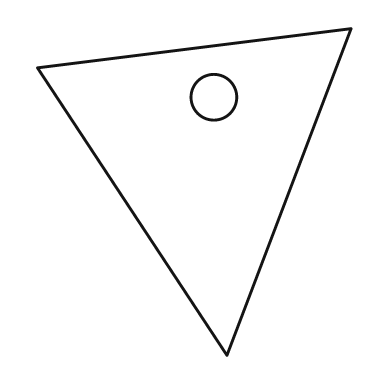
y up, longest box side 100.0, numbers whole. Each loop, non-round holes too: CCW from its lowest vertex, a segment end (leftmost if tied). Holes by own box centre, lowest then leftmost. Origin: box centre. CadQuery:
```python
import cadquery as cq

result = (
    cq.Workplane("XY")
    .moveTo(10.0, -50.0)
    .lineTo(48.0, 50.0)
    .lineTo(-48.0, 38.0)
    .close()
    .moveTo(6.0, 29.0)
    .circle(7.0)
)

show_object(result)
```